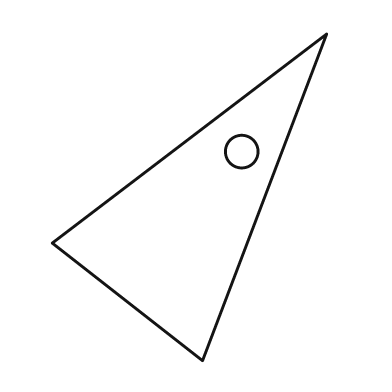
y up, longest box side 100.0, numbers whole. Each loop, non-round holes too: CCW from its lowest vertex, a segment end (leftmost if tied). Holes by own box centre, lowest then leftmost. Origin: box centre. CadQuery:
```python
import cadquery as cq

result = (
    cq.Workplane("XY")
    .moveTo(4.0, -50.0)
    .lineTo(42.0, 50.0)
    .lineTo(-42.0, -14.0)
    .close()
    .moveTo(16.0, 14.0)
    .circle(5.0)
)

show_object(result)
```